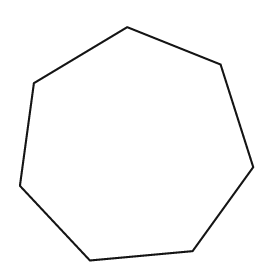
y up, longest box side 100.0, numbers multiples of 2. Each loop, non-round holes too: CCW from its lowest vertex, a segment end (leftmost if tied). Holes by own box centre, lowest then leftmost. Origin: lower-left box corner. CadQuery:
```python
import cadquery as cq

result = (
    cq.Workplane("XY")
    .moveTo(30.0, 0.0)
    .lineTo(74.0, 4.0)
    .lineTo(100.0, 40.0)
    .lineTo(86.0, 84.0)
    .lineTo(46.0, 100.0)
    .lineTo(6.0, 76.0)
    .lineTo(0.0, 32.0)
    .close()
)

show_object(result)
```